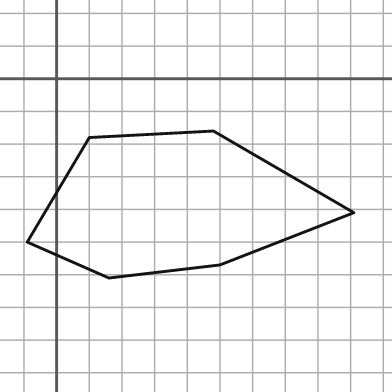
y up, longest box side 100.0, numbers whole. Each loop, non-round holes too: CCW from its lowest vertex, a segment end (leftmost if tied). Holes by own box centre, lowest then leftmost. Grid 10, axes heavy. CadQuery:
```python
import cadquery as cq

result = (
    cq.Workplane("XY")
    .moveTo(16.0, -61.0)
    .lineTo(50.0, -57.0)
    .lineTo(91.0, -41.0)
    .lineTo(48.0, -16.0)
    .lineTo(10.0, -18.0)
    .lineTo(-9.0, -50.0)
    .close()
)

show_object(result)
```